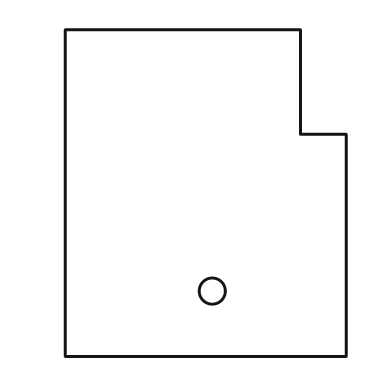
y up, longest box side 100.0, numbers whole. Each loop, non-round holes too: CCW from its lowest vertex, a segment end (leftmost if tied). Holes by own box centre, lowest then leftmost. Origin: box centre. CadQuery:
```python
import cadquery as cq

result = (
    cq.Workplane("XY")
    .moveTo(-43.0, -50.0)
    .lineTo(43.0, -50.0)
    .lineTo(43.0, 18.0)
    .lineTo(29.0, 18.0)
    .lineTo(29.0, 50.0)
    .lineTo(-43.0, 50.0)
    .close()
    .moveTo(2.0, -30.0)
    .circle(4.0)
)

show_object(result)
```